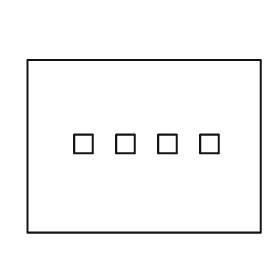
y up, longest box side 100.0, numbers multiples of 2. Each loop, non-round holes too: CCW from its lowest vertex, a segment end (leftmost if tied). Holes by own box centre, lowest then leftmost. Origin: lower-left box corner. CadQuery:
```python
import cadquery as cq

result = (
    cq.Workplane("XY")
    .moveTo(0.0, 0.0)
    .lineTo(100.0, 0.0)
    .lineTo(100.0, 74.0)
    .lineTo(0.0, 74.0)
    .close()
    .moveTo(20.0, 34.0)
    .lineTo(28.0, 34.0)
    .lineTo(28.0, 42.0)
    .lineTo(20.0, 42.0)
    .close()
    .moveTo(38.0, 34.0)
    .lineTo(46.0, 34.0)
    .lineTo(46.0, 42.0)
    .lineTo(38.0, 42.0)
    .close()
    .moveTo(56.0, 34.0)
    .lineTo(64.0, 34.0)
    .lineTo(64.0, 42.0)
    .lineTo(56.0, 42.0)
    .close()
    .moveTo(74.0, 34.0)
    .lineTo(82.0, 34.0)
    .lineTo(82.0, 42.0)
    .lineTo(74.0, 42.0)
    .close()
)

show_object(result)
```